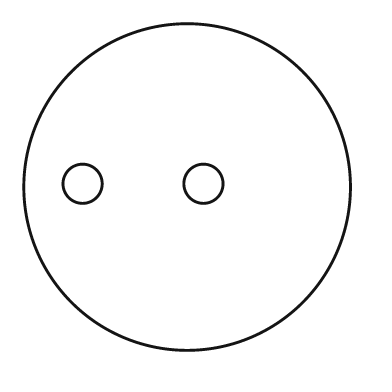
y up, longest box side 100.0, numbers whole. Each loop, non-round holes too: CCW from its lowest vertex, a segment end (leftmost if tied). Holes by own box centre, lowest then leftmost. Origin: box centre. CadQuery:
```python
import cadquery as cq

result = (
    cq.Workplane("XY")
    .moveTo(0.0, 0.0)
    .circle(50.0)
    .moveTo(-32.0, 1.0)
    .circle(6.0)
    .moveTo(5.0, 1.0)
    .circle(6.0)
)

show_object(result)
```